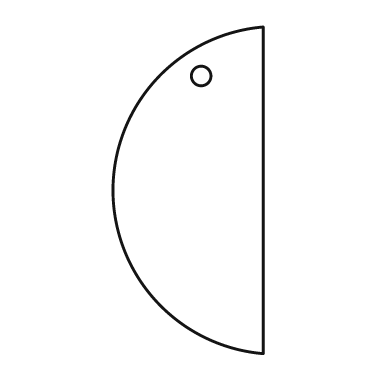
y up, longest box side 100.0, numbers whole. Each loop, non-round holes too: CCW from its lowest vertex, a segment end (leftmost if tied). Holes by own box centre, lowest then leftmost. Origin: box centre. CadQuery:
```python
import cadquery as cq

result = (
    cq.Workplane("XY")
    .moveTo(23.0, -50.0)
    .lineTo(23.0, 50.0)
    .threePointArc((-23.0, 0.0), (23.0, -50.0))
    .close()
    .moveTo(4.0, 35.0)
    .circle(3.0)
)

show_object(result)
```